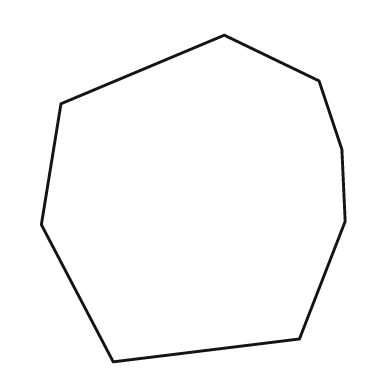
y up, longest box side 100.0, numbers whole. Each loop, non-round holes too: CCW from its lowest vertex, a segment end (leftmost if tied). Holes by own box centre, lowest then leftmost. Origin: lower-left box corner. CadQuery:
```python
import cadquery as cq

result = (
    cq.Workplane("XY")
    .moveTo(22.0, 0.0)
    .lineTo(79.0, 7.0)
    .lineTo(93.0, 43.0)
    .lineTo(92.0, 65.0)
    .lineTo(85.0, 86.0)
    .lineTo(56.0, 100.0)
    .lineTo(6.0, 79.0)
    .lineTo(0.0, 42.0)
    .close()
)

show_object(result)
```